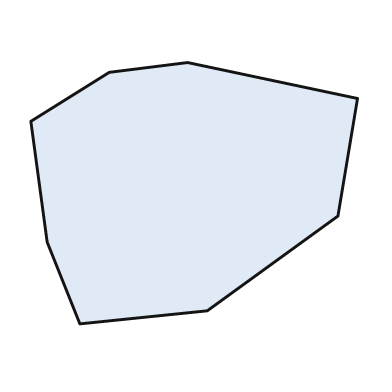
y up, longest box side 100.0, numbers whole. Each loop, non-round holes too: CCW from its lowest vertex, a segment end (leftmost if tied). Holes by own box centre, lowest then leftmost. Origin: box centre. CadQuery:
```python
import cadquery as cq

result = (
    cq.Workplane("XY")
    .moveTo(-35.0, -40.0)
    .lineTo(4.0, -36.0)
    .lineTo(44.0, -7.0)
    .lineTo(50.0, 29.0)
    .lineTo(-2.0, 40.0)
    .lineTo(-26.0, 37.0)
    .lineTo(-50.0, 22.0)
    .lineTo(-45.0, -15.0)
    .close()
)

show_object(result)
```